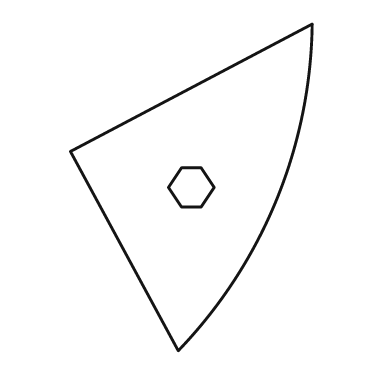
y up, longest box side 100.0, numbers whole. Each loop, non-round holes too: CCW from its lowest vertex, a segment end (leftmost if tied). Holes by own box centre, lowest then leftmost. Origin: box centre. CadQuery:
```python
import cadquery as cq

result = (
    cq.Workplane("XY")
    .moveTo(-4.0, -50.0)
    .threePointArc((26.0, -4.0), (37.0, 50.0))
    .lineTo(-37.0, 11.0)
    .close()
    .moveTo(-3.0, -6.0)
    .lineTo(3.0, -6.0)
    .lineTo(7.0, 0.0)
    .lineTo(3.0, 6.0)
    .lineTo(-3.0, 6.0)
    .lineTo(-7.0, 0.0)
    .close()
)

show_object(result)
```